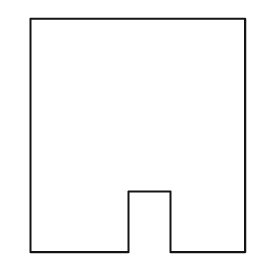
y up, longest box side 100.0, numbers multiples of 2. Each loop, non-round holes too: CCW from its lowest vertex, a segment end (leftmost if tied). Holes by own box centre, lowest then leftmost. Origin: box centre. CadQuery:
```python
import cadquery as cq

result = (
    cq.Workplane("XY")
    .moveTo(-46.0, -50.0)
    .lineTo(-4.0, -50.0)
    .lineTo(-4.0, -24.0)
    .lineTo(14.0, -24.0)
    .lineTo(14.0, -50.0)
    .lineTo(46.0, -50.0)
    .lineTo(46.0, 50.0)
    .lineTo(-46.0, 50.0)
    .close()
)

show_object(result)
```